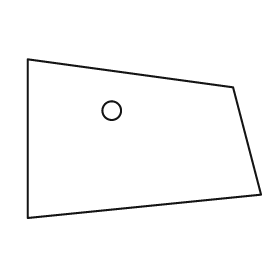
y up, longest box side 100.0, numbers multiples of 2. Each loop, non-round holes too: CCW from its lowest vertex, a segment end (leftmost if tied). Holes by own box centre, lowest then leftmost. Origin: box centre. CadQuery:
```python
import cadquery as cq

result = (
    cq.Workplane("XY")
    .moveTo(-50.0, -34.0)
    .lineTo(50.0, -24.0)
    .lineTo(38.0, 22.0)
    .lineTo(-50.0, 34.0)
    .close()
    .moveTo(-14.0, 12.0)
    .circle(4.0)
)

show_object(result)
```